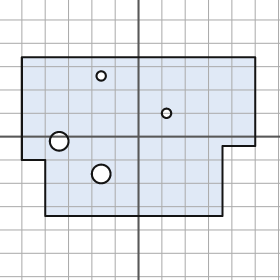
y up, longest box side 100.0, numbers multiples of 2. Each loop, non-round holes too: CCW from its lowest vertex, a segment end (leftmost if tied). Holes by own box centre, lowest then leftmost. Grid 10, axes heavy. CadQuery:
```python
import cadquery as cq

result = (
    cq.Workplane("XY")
    .moveTo(-40.0, -34.0)
    .lineTo(36.0, -34.0)
    .lineTo(36.0, -4.0)
    .lineTo(50.0, -4.0)
    .lineTo(50.0, 34.0)
    .lineTo(-50.0, 34.0)
    .lineTo(-50.0, -10.0)
    .lineTo(-40.0, -10.0)
    .close()
    .moveTo(-16.0, -16.0)
    .circle(4.0)
    .moveTo(-34.0, -2.0)
    .circle(4.0)
    .moveTo(12.0, 10.0)
    .circle(2.0)
    .moveTo(-16.0, 26.0)
    .circle(2.0)
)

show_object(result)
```